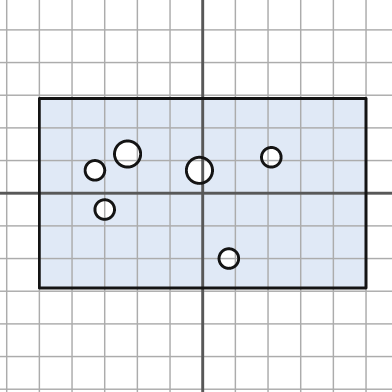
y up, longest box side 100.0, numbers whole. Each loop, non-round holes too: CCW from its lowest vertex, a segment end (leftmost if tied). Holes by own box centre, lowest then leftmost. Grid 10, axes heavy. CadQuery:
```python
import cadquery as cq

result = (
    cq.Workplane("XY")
    .moveTo(-50.0, -29.0)
    .lineTo(50.0, -29.0)
    .lineTo(50.0, 29.0)
    .lineTo(-50.0, 29.0)
    .close()
    .moveTo(8.0, -20.0)
    .circle(3.0)
    .moveTo(-30.0, -5.0)
    .circle(3.0)
    .moveTo(-33.0, 7.0)
    .circle(3.0)
    .moveTo(-1.0, 7.0)
    .circle(4.0)
    .moveTo(21.0, 11.0)
    .circle(3.0)
    .moveTo(-23.0, 12.0)
    .circle(4.0)
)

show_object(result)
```